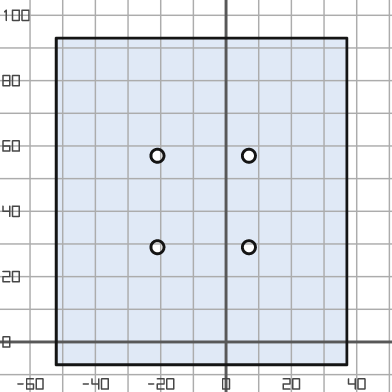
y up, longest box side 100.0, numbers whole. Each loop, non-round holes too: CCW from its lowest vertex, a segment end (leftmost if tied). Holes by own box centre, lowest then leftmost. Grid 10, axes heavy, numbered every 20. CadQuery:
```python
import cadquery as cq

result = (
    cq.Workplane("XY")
    .moveTo(-52.0, -7.0)
    .lineTo(37.0, -7.0)
    .lineTo(37.0, 93.0)
    .lineTo(-52.0, 93.0)
    .close()
    .moveTo(-21.0, 29.0)
    .circle(2.0)
    .moveTo(7.0, 29.0)
    .circle(2.0)
    .moveTo(-21.0, 57.0)
    .circle(2.0)
    .moveTo(7.0, 57.0)
    .circle(2.0)
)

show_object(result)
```